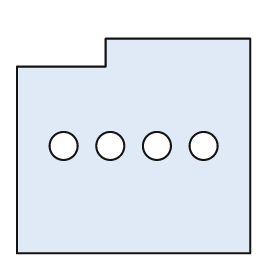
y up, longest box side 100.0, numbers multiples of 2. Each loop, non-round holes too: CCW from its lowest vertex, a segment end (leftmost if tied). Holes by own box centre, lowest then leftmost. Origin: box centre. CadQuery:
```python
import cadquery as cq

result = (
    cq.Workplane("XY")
    .moveTo(-50.0, -46.0)
    .lineTo(50.0, -46.0)
    .lineTo(50.0, 46.0)
    .lineTo(-12.0, 46.0)
    .lineTo(-12.0, 34.0)
    .lineTo(-50.0, 34.0)
    .close()
    .moveTo(-30.0, 0.0)
    .circle(6.0)
    .moveTo(-10.0, 0.0)
    .circle(6.0)
    .moveTo(10.0, 0.0)
    .circle(6.0)
    .moveTo(30.0, 0.0)
    .circle(6.0)
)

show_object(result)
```